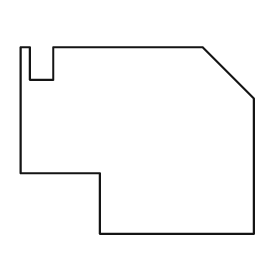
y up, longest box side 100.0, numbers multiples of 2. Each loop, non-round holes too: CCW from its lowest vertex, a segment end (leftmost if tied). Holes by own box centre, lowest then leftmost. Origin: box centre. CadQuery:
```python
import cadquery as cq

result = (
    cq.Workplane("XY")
    .moveTo(-16.0, -40.0)
    .lineTo(50.0, -40.0)
    .lineTo(50.0, 18.0)
    .lineTo(28.0, 40.0)
    .lineTo(-36.0, 40.0)
    .lineTo(-36.0, 26.0)
    .lineTo(-46.0, 26.0)
    .lineTo(-46.0, 40.0)
    .lineTo(-50.0, 40.0)
    .lineTo(-50.0, -14.0)
    .lineTo(-16.0, -14.0)
    .close()
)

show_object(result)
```